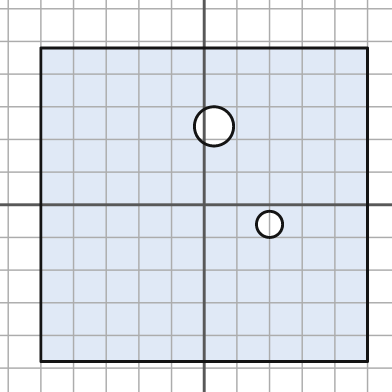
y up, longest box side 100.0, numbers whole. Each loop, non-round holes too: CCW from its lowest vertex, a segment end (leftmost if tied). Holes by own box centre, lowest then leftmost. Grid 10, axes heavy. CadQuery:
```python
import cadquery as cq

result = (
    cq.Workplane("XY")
    .moveTo(-50.0, -48.0)
    .lineTo(50.0, -48.0)
    .lineTo(50.0, 48.0)
    .lineTo(-50.0, 48.0)
    .close()
    .moveTo(20.0, -6.0)
    .circle(4.0)
    .moveTo(3.0, 24.0)
    .circle(6.0)
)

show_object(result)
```